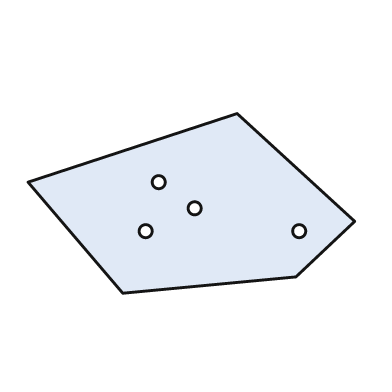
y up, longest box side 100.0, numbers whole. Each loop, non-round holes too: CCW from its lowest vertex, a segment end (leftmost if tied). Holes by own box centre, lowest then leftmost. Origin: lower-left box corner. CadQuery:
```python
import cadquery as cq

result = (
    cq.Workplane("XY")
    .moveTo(29.0, 0.0)
    .lineTo(82.0, 5.0)
    .lineTo(100.0, 22.0)
    .lineTo(64.0, 55.0)
    .lineTo(0.0, 34.0)
    .close()
    .moveTo(36.0, 19.0)
    .circle(2.0)
    .moveTo(83.0, 19.0)
    .circle(2.0)
    .moveTo(51.0, 26.0)
    .circle(2.0)
    .moveTo(40.0, 34.0)
    .circle(2.0)
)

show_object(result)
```